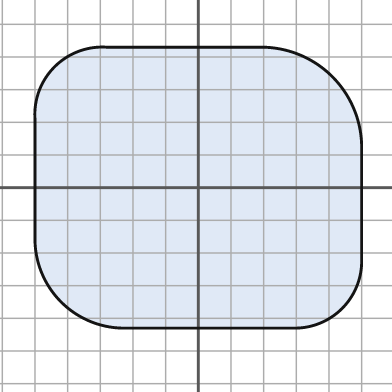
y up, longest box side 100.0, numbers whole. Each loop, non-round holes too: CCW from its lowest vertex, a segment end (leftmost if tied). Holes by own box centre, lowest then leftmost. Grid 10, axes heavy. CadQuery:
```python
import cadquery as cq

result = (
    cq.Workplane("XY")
    .moveTo(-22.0, -43.0)
    .lineTo(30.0, -43.0)
    .threePointArc((44.0, -37.0), (50.0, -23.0))
    .lineTo(50.0, 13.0)
    .threePointArc((41.0, 34.0), (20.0, 43.0))
    .lineTo(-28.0, 43.0)
    .threePointArc((-44.0, 37.0), (-50.0, 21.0))
    .lineTo(-50.0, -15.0)
    .threePointArc((-42.0, -35.0), (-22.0, -43.0))
    .close()
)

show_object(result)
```